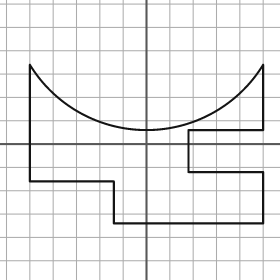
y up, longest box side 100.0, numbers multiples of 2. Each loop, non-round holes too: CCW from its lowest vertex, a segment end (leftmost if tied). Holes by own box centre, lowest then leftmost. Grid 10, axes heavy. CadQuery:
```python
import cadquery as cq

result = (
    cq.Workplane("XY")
    .moveTo(-14.0, -34.0)
    .lineTo(50.0, -34.0)
    .lineTo(50.0, -12.0)
    .lineTo(18.0, -12.0)
    .lineTo(18.0, 6.0)
    .lineTo(50.0, 6.0)
    .lineTo(50.0, 34.0)
    .threePointArc((0.0, 6.0), (-50.0, 34.0))
    .lineTo(-50.0, -16.0)
    .lineTo(-14.0, -16.0)
    .close()
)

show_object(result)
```